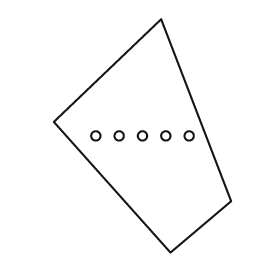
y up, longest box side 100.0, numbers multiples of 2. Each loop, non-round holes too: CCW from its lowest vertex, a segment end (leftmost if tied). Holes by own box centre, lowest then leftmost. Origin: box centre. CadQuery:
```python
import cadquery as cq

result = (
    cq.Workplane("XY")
    .moveTo(12.0, -50.0)
    .lineTo(38.0, -28.0)
    .lineTo(8.0, 50.0)
    .lineTo(-38.0, 6.0)
    .close()
    .moveTo(-20.0, 0.0)
    .circle(2.0)
    .moveTo(-10.0, 0.0)
    .circle(2.0)
    .moveTo(0.0, 0.0)
    .circle(2.0)
    .moveTo(10.0, 0.0)
    .circle(2.0)
    .moveTo(20.0, 0.0)
    .circle(2.0)
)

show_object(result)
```